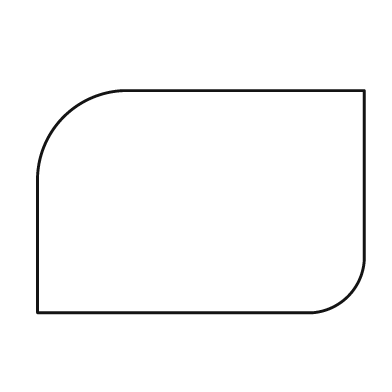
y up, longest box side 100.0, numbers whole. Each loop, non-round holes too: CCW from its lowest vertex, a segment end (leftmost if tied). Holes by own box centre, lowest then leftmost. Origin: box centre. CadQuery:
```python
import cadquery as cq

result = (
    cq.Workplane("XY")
    .moveTo(-50.0, -34.0)
    .lineTo(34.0, -34.0)
    .threePointArc((45.0, -29.0), (50.0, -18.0))
    .lineTo(50.0, 34.0)
    .lineTo(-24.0, 34.0)
    .threePointArc((-42.0, 26.0), (-50.0, 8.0))
    .close()
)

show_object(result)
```